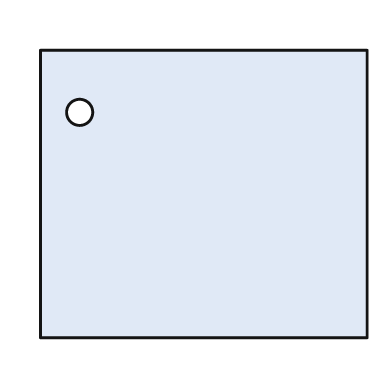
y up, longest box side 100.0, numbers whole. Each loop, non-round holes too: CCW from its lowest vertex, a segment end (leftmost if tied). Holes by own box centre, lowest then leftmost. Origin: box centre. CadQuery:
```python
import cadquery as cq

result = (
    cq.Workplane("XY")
    .moveTo(-50.0, -44.0)
    .lineTo(50.0, -44.0)
    .lineTo(50.0, 44.0)
    .lineTo(-50.0, 44.0)
    .close()
    .moveTo(-38.0, 25.0)
    .circle(4.0)
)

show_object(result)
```